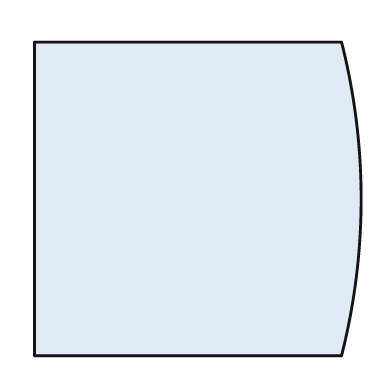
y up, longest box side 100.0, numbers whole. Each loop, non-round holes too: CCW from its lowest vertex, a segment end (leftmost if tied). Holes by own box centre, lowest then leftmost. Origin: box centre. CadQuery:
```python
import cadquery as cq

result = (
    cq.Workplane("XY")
    .moveTo(-50.0, -48.0)
    .lineTo(44.0, -48.0)
    .threePointArc((50.0, 0.0), (44.0, 48.0))
    .lineTo(-50.0, 48.0)
    .close()
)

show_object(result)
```